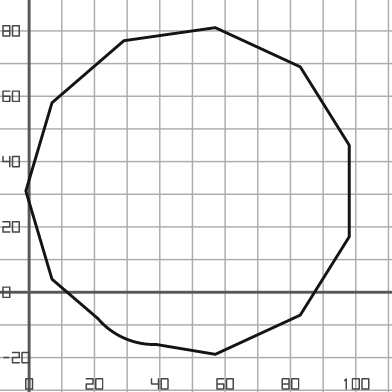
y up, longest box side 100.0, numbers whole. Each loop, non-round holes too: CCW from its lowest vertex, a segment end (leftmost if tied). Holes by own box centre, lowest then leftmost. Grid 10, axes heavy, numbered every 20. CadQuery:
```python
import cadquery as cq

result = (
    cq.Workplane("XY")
    .moveTo(57.0, -19.0)
    .lineTo(83.0, -7.0)
    .lineTo(98.0, 17.0)
    .lineTo(98.0, 45.0)
    .lineTo(83.0, 69.0)
    .lineTo(57.0, 81.0)
    .lineTo(29.0, 77.0)
    .lineTo(7.0, 58.0)
    .lineTo(-1.0, 31.0)
    .lineTo(7.0, 4.0)
    .lineTo(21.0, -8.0)
    .threePointArc((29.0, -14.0), (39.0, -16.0))
    .close()
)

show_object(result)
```